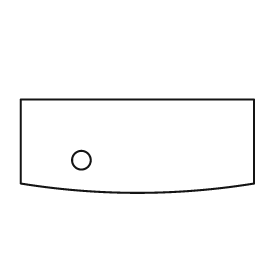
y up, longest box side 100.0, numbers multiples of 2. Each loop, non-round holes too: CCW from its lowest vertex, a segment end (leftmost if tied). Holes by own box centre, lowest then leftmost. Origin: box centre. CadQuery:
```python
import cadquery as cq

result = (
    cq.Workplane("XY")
    .moveTo(-50.0, -16.0)
    .threePointArc((0.0, -20.0), (50.0, -16.0))
    .lineTo(50.0, 20.0)
    .lineTo(-50.0, 20.0)
    .close()
    .moveTo(-24.0, -6.0)
    .circle(4.0)
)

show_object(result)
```